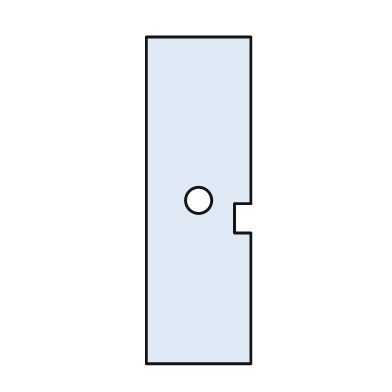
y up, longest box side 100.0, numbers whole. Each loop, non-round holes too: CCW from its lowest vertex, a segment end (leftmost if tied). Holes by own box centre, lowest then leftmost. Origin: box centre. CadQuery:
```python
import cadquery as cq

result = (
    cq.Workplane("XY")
    .moveTo(-16.0, -50.0)
    .lineTo(16.0, -50.0)
    .lineTo(16.0, -10.0)
    .lineTo(11.0, -10.0)
    .lineTo(11.0, -1.0)
    .lineTo(16.0, -1.0)
    .lineTo(16.0, 50.0)
    .lineTo(-16.0, 50.0)
    .close()
    .moveTo(0.0, 0.0)
    .circle(4.0)
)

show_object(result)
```